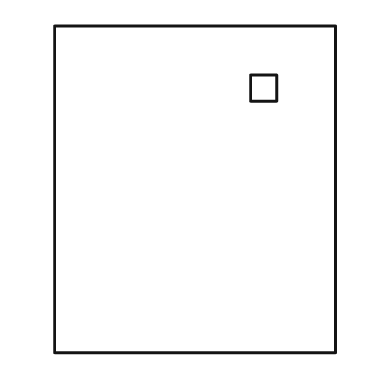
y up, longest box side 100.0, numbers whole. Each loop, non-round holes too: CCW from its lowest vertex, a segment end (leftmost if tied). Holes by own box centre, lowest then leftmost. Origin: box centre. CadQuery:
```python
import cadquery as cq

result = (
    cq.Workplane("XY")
    .moveTo(-43.0, -50.0)
    .lineTo(43.0, -50.0)
    .lineTo(43.0, 50.0)
    .lineTo(-43.0, 50.0)
    .close()
    .moveTo(17.0, 27.0)
    .lineTo(25.0, 27.0)
    .lineTo(25.0, 35.0)
    .lineTo(17.0, 35.0)
    .close()
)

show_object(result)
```